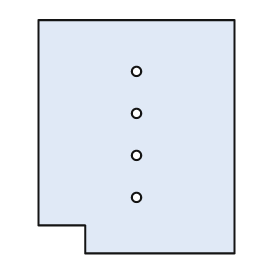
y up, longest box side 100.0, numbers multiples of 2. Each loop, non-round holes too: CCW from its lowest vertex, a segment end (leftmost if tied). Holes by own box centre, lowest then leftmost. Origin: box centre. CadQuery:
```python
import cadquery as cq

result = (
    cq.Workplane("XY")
    .moveTo(-22.0, -50.0)
    .lineTo(42.0, -50.0)
    .lineTo(42.0, 50.0)
    .lineTo(-42.0, 50.0)
    .lineTo(-42.0, -38.0)
    .lineTo(-22.0, -38.0)
    .close()
    .moveTo(0.0, -26.0)
    .circle(2.0)
    .moveTo(0.0, -8.0)
    .circle(2.0)
    .moveTo(0.0, 10.0)
    .circle(2.0)
    .moveTo(0.0, 28.0)
    .circle(2.0)
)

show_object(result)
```